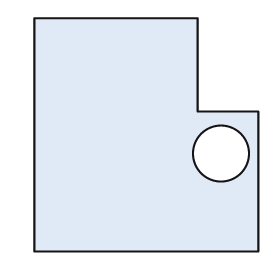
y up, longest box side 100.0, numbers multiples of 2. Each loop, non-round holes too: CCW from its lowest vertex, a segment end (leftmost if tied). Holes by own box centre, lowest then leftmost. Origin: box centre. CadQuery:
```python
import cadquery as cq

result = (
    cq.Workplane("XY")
    .moveTo(-48.0, -50.0)
    .lineTo(48.0, -50.0)
    .lineTo(48.0, 10.0)
    .lineTo(22.0, 10.0)
    .lineTo(22.0, 50.0)
    .lineTo(-48.0, 50.0)
    .close()
    .moveTo(32.0, -8.0)
    .circle(12.0)
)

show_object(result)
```